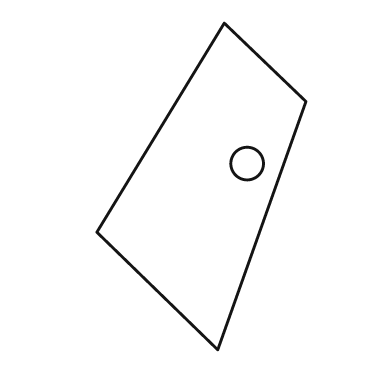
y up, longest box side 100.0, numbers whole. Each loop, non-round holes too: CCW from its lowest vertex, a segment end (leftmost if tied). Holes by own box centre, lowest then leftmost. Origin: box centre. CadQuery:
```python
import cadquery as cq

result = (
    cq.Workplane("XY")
    .moveTo(5.0, -50.0)
    .lineTo(32.0, 26.0)
    .lineTo(7.0, 50.0)
    .lineTo(-32.0, -14.0)
    .close()
    .moveTo(14.0, 7.0)
    .circle(5.0)
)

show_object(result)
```